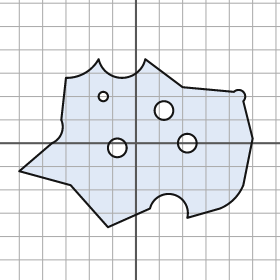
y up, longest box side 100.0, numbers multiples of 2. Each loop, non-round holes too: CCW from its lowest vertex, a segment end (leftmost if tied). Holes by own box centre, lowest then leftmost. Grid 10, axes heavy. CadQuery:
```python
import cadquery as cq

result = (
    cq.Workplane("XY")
    .moveTo(-12.0, -36.0)
    .lineTo(6.0, -28.0)
    .threePointArc((16.0, -22.0), (22.0, -32.0))
    .lineTo(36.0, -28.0)
    .threePointArc((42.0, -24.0), (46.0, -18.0))
    .lineTo(50.0, 2.0)
    .lineTo(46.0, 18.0)
    .threePointArc((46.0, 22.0), (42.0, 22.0))
    .lineTo(20.0, 24.0)
    .lineTo(4.0, 36.0)
    .threePointArc((-6.0, 28.0), (-16.0, 36.0))
    .threePointArc((-22.0, 30.0), (-30.0, 28.0))
    .lineTo(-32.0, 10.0)
    .threePointArc((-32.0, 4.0), (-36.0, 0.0))
    .lineTo(-50.0, -12.0)
    .lineTo(-28.0, -18.0)
    .close()
    .moveTo(-8.0, -2.0)
    .circle(4.0)
    .moveTo(22.0, 0.0)
    .circle(4.0)
    .moveTo(12.0, 14.0)
    .circle(4.0)
    .moveTo(-14.0, 20.0)
    .circle(2.0)
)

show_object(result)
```